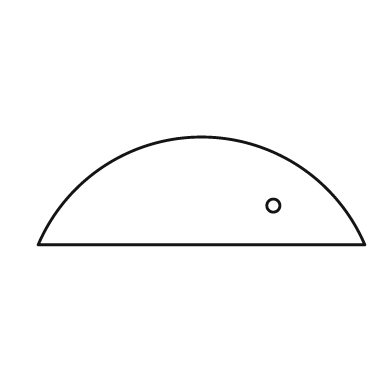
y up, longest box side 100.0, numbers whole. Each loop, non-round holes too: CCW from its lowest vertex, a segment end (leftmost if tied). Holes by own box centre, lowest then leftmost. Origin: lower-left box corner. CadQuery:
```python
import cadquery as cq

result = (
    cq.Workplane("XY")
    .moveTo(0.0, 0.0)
    .lineTo(100.0, 0.0)
    .threePointArc((50.0, 33.0), (0.0, 0.0))
    .close()
    .moveTo(72.0, 12.0)
    .circle(2.0)
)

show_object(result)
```